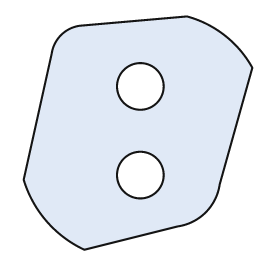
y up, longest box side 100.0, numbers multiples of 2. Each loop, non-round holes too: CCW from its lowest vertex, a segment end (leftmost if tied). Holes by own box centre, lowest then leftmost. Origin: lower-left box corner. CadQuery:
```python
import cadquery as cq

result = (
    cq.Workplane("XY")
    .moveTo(26.0, 0.0)
    .lineTo(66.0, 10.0)
    .threePointArc((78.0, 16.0), (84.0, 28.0))
    .lineTo(98.0, 78.0)
    .threePointArc((86.0, 92.0), (70.0, 100.0))
    .lineTo(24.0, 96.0)
    .threePointArc((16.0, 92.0), (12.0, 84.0))
    .lineTo(0.0, 30.0)
    .threePointArc((10.0, 12.0), (26.0, 0.0))
    .close()
    .moveTo(50.0, 32.0)
    .circle(10.0)
    .moveTo(50.0, 70.0)
    .circle(10.0)
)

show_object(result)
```